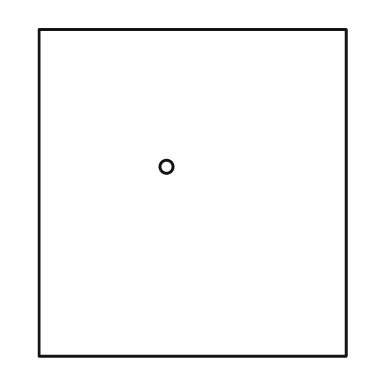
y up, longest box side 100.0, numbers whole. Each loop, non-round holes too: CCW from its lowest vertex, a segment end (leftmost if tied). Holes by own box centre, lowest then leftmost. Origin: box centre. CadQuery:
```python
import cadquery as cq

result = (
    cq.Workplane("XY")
    .moveTo(-47.0, -50.0)
    .lineTo(47.0, -50.0)
    .lineTo(47.0, 50.0)
    .lineTo(-47.0, 50.0)
    .close()
    .moveTo(-8.0, 8.0)
    .circle(2.0)
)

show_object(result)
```